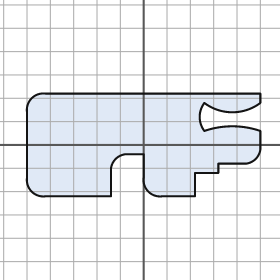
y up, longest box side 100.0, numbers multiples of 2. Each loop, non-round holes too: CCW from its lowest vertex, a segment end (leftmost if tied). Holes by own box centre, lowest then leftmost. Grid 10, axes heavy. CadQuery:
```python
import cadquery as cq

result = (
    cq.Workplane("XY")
    .moveTo(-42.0, -22.0)
    .lineTo(-14.0, -22.0)
    .lineTo(-14.0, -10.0)
    .threePointArc((-12.0, -6.0), (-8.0, -4.0))
    .lineTo(0.0, -4.0)
    .lineTo(0.0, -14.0)
    .threePointArc((2.0, -20.0), (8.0, -22.0))
    .lineTo(22.0, -22.0)
    .lineTo(22.0, -12.0)
    .lineTo(32.0, -12.0)
    .lineTo(32.0, -8.0)
    .lineTo(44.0, -8.0)
    .threePointArc((48.0, -6.0), (50.0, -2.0))
    .lineTo(50.0, 6.0)
    .threePointArc((38.0, 8.0), (26.0, 6.0))
    .threePointArc((24.0, 12.0), (26.0, 18.0))
    .threePointArc((38.0, 14.0), (50.0, 18.0))
    .lineTo(50.0, 22.0)
    .lineTo(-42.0, 22.0)
    .threePointArc((-48.0, 20.0), (-50.0, 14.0))
    .lineTo(-50.0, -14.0)
    .threePointArc((-48.0, -20.0), (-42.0, -22.0))
    .close()
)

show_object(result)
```